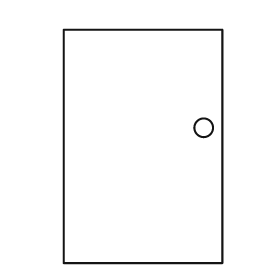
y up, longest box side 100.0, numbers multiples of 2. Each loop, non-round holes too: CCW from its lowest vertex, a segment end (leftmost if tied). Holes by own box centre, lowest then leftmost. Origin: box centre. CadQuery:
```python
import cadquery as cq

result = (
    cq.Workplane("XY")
    .moveTo(-34.0, -50.0)
    .lineTo(34.0, -50.0)
    .lineTo(34.0, 50.0)
    .lineTo(-34.0, 50.0)
    .close()
    .moveTo(26.0, 8.0)
    .circle(4.0)
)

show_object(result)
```